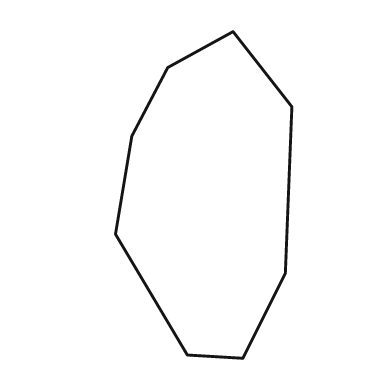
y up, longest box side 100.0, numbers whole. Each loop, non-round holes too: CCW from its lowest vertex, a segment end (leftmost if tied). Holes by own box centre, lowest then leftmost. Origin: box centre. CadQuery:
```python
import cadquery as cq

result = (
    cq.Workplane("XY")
    .moveTo(12.0, -50.0)
    .lineTo(25.0, -24.0)
    .lineTo(27.0, 27.0)
    .lineTo(9.0, 50.0)
    .lineTo(-11.0, 39.0)
    .lineTo(-22.0, 18.0)
    .lineTo(-27.0, -12.0)
    .lineTo(-5.0, -49.0)
    .close()
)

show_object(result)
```